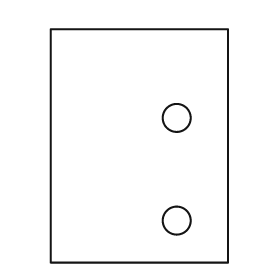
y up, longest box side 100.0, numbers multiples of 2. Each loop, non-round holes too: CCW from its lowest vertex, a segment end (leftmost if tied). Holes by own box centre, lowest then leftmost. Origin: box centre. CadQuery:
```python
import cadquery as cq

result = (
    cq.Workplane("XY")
    .moveTo(-38.0, -50.0)
    .lineTo(38.0, -50.0)
    .lineTo(38.0, 50.0)
    .lineTo(-38.0, 50.0)
    .close()
    .moveTo(16.0, -32.0)
    .circle(6.0)
    .moveTo(16.0, 12.0)
    .circle(6.0)
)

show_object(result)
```